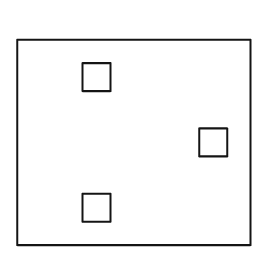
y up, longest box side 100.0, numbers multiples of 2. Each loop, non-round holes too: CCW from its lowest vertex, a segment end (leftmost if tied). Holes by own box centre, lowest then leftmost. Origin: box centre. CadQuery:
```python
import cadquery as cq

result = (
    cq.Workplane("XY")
    .moveTo(-50.0, -44.0)
    .lineTo(50.0, -44.0)
    .lineTo(50.0, 44.0)
    .lineTo(-50.0, 44.0)
    .close()
    .moveTo(-22.0, -34.0)
    .lineTo(-10.0, -34.0)
    .lineTo(-10.0, -22.0)
    .lineTo(-22.0, -22.0)
    .close()
    .moveTo(28.0, -6.0)
    .lineTo(40.0, -6.0)
    .lineTo(40.0, 6.0)
    .lineTo(28.0, 6.0)
    .close()
    .moveTo(-22.0, 22.0)
    .lineTo(-10.0, 22.0)
    .lineTo(-10.0, 34.0)
    .lineTo(-22.0, 34.0)
    .close()
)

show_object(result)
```